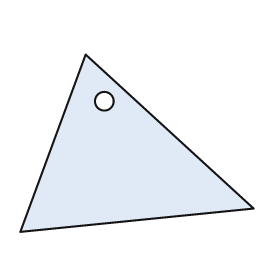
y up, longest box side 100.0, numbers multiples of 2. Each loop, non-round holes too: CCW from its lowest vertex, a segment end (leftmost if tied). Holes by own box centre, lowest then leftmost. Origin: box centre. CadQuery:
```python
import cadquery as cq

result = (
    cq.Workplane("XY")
    .moveTo(-50.0, -38.0)
    .lineTo(50.0, -28.0)
    .lineTo(-22.0, 38.0)
    .close()
    .moveTo(-14.0, 18.0)
    .circle(4.0)
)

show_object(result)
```